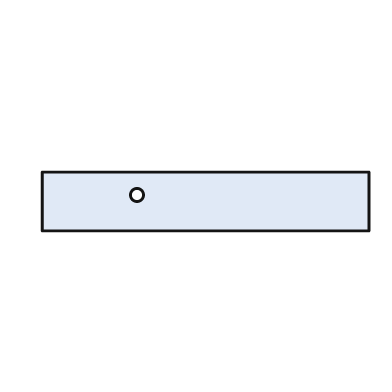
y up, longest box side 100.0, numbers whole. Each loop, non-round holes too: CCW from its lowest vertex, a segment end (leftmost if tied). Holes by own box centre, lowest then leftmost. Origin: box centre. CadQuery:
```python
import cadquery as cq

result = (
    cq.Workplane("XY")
    .moveTo(-50.0, -9.0)
    .lineTo(50.0, -9.0)
    .lineTo(50.0, 9.0)
    .lineTo(-50.0, 9.0)
    .close()
    .moveTo(-21.0, 2.0)
    .circle(2.0)
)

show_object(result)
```